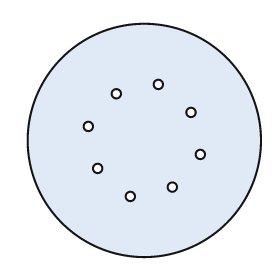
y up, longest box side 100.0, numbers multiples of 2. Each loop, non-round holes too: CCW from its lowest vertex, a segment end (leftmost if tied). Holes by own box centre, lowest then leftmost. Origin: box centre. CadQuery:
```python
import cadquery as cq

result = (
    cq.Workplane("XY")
    .moveTo(0.0, 0.0)
    .circle(50.0)
    .moveTo(-6.0, -24.0)
    .circle(2.0)
    .moveTo(12.0, -20.0)
    .circle(2.0)
    .moveTo(-20.0, -12.0)
    .circle(2.0)
    .moveTo(24.0, -6.0)
    .circle(2.0)
    .moveTo(-24.0, 6.0)
    .circle(2.0)
    .moveTo(20.0, 12.0)
    .circle(2.0)
    .moveTo(-12.0, 20.0)
    .circle(2.0)
    .moveTo(6.0, 24.0)
    .circle(2.0)
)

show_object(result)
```